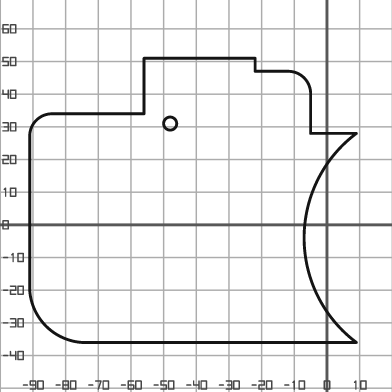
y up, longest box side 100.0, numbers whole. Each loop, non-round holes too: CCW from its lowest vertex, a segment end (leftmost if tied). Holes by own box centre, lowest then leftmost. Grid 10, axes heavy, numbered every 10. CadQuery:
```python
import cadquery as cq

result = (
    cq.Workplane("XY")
    .moveTo(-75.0, -36.0)
    .lineTo(9.0, -36.0)
    .threePointArc((-7.0, -4.0), (9.0, 28.0))
    .lineTo(-5.0, 28.0)
    .lineTo(-5.0, 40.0)
    .threePointArc((-7.0, 45.0), (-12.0, 47.0))
    .lineTo(-22.0, 47.0)
    .lineTo(-22.0, 51.0)
    .lineTo(-56.0, 51.0)
    .lineTo(-56.0, 34.0)
    .lineTo(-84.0, 34.0)
    .threePointArc((-89.0, 32.0), (-91.0, 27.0))
    .lineTo(-91.0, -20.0)
    .threePointArc((-86.0, -31.0), (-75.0, -36.0))
    .close()
    .moveTo(-48.0, 31.0)
    .circle(2.0)
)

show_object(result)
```